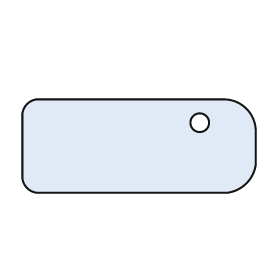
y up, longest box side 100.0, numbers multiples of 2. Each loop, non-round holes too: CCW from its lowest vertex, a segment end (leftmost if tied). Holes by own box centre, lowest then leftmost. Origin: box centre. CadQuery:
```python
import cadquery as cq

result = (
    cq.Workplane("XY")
    .moveTo(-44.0, -20.0)
    .lineTo(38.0, -20.0)
    .threePointArc((46.0, -16.0), (50.0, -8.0))
    .lineTo(50.0, 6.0)
    .threePointArc((46.0, 16.0), (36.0, 20.0))
    .lineTo(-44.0, 20.0)
    .threePointArc((-48.0, 18.0), (-50.0, 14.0))
    .lineTo(-50.0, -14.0)
    .threePointArc((-48.0, -18.0), (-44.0, -20.0))
    .close()
    .moveTo(26.0, 10.0)
    .circle(4.0)
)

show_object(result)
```